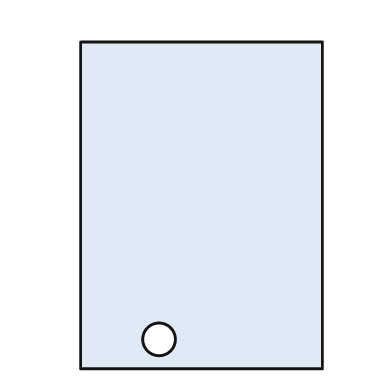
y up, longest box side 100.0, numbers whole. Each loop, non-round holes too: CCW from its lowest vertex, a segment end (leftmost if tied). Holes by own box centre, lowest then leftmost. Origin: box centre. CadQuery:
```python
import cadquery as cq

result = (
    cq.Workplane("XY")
    .moveTo(-37.0, -50.0)
    .lineTo(37.0, -50.0)
    .lineTo(37.0, 50.0)
    .lineTo(-37.0, 50.0)
    .close()
    .moveTo(-13.0, -41.0)
    .circle(5.0)
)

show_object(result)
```